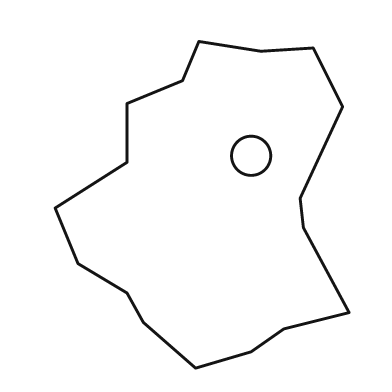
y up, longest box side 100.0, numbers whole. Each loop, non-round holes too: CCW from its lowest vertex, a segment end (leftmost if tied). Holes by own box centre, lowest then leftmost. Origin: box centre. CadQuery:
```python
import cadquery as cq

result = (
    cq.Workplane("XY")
    .moveTo(-2.0, -50.0)
    .lineTo(15.0, -45.0)
    .lineTo(25.0, -38.0)
    .lineTo(45.0, -33.0)
    .lineTo(31.0, -7.0)
    .lineTo(30.0, 2.0)
    .lineTo(43.0, 30.0)
    .lineTo(34.0, 48.0)
    .lineTo(18.0, 47.0)
    .lineTo(-1.0, 50.0)
    .lineTo(-6.0, 38.0)
    .lineTo(-23.0, 31.0)
    .lineTo(-23.0, 13.0)
    .lineTo(-45.0, -1.0)
    .lineTo(-38.0, -18.0)
    .lineTo(-23.0, -27.0)
    .lineTo(-18.0, -36.0)
    .close()
    .moveTo(15.0, 15.0)
    .circle(6.0)
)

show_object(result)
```